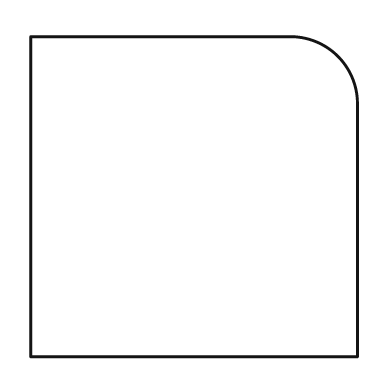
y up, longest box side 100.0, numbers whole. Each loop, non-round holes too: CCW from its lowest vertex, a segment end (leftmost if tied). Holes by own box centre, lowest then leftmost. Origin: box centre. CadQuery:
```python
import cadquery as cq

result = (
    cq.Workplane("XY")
    .moveTo(-50.0, -49.0)
    .lineTo(50.0, -49.0)
    .lineTo(50.0, 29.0)
    .threePointArc((44.0, 43.0), (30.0, 49.0))
    .lineTo(-50.0, 49.0)
    .close()
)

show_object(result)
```